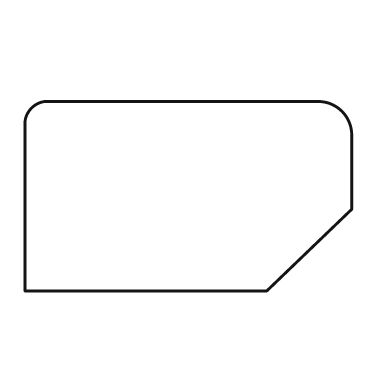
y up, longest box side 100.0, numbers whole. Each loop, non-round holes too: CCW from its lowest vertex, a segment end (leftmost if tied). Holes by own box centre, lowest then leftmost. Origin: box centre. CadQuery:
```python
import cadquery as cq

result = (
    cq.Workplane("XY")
    .moveTo(-50.0, -29.0)
    .lineTo(24.0, -29.0)
    .lineTo(50.0, -4.0)
    .lineTo(50.0, 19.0)
    .threePointArc((47.0, 26.0), (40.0, 29.0))
    .lineTo(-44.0, 29.0)
    .threePointArc((-48.0, 27.0), (-50.0, 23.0))
    .close()
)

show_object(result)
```